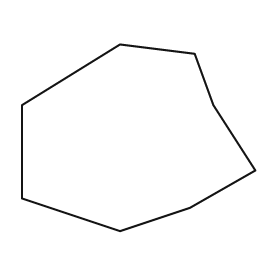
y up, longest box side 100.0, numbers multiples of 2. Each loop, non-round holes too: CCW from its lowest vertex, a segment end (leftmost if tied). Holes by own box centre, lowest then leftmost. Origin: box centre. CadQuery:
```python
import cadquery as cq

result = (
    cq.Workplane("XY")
    .moveTo(-8.0, -40.0)
    .lineTo(22.0, -30.0)
    .lineTo(50.0, -14.0)
    .lineTo(32.0, 14.0)
    .lineTo(24.0, 36.0)
    .lineTo(-8.0, 40.0)
    .lineTo(-50.0, 14.0)
    .lineTo(-50.0, -26.0)
    .close()
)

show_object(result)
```